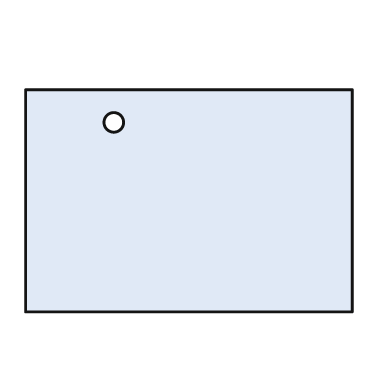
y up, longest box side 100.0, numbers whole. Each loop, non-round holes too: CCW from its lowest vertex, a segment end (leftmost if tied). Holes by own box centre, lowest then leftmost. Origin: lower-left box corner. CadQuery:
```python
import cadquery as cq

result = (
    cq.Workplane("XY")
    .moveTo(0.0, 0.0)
    .lineTo(100.0, 0.0)
    .lineTo(100.0, 68.0)
    .lineTo(0.0, 68.0)
    .close()
    .moveTo(27.0, 58.0)
    .circle(3.0)
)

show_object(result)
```